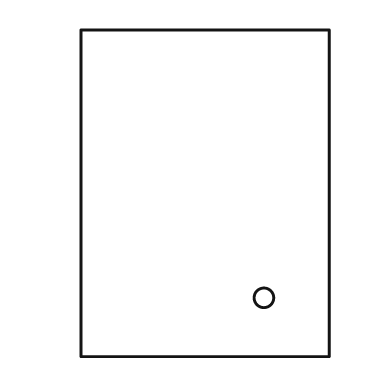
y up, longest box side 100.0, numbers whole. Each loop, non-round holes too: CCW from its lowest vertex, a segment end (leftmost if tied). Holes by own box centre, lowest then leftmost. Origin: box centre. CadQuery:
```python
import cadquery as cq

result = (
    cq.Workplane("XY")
    .moveTo(-38.0, -50.0)
    .lineTo(38.0, -50.0)
    .lineTo(38.0, 50.0)
    .lineTo(-38.0, 50.0)
    .close()
    .moveTo(18.0, -32.0)
    .circle(3.0)
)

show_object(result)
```